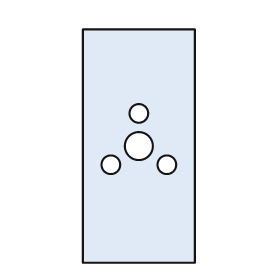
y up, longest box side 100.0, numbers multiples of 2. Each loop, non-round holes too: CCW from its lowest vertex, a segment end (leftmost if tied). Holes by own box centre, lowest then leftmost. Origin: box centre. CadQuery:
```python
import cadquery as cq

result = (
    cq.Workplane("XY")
    .moveTo(-24.0, -50.0)
    .lineTo(24.0, -50.0)
    .lineTo(24.0, 50.0)
    .lineTo(-24.0, 50.0)
    .close()
    .moveTo(-12.0, -8.0)
    .circle(4.0)
    .moveTo(12.0, -8.0)
    .circle(4.0)
    .moveTo(0.0, 0.0)
    .circle(6.0)
    .moveTo(0.0, 14.0)
    .circle(4.0)
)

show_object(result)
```